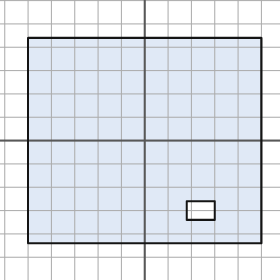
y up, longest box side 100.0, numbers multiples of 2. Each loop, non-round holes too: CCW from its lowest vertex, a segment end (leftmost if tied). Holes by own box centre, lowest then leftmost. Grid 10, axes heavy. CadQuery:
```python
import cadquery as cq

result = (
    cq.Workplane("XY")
    .moveTo(-50.0, -44.0)
    .lineTo(50.0, -44.0)
    .lineTo(50.0, 44.0)
    .lineTo(-50.0, 44.0)
    .close()
    .moveTo(18.0, -34.0)
    .lineTo(30.0, -34.0)
    .lineTo(30.0, -26.0)
    .lineTo(18.0, -26.0)
    .close()
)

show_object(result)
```